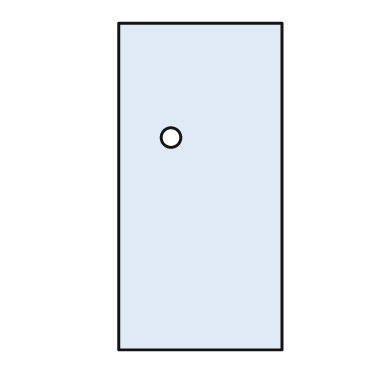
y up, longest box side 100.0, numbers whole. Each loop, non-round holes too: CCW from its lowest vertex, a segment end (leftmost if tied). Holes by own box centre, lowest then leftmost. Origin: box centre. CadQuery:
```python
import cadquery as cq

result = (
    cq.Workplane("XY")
    .moveTo(-25.0, -50.0)
    .lineTo(25.0, -50.0)
    .lineTo(25.0, 50.0)
    .lineTo(-25.0, 50.0)
    .close()
    .moveTo(-9.0, 15.0)
    .circle(3.0)
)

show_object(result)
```